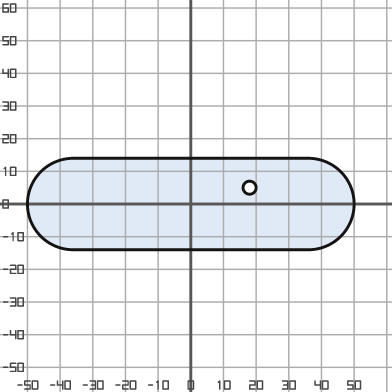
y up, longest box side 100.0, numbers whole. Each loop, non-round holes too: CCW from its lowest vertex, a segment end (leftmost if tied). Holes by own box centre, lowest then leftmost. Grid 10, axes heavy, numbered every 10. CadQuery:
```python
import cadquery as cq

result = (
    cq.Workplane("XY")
    .moveTo(-36.0, -14.0)
    .lineTo(36.0, -14.0)
    .threePointArc((50.0, 0.0), (36.0, 14.0))
    .lineTo(-36.0, 14.0)
    .threePointArc((-50.0, 0.0), (-36.0, -14.0))
    .close()
    .moveTo(18.0, 5.0)
    .circle(2.0)
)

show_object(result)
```